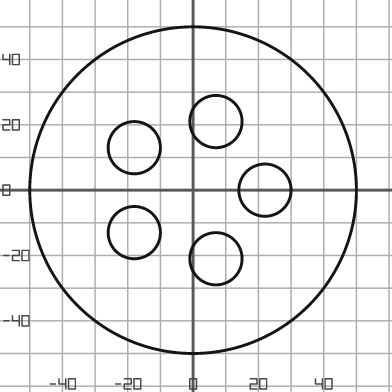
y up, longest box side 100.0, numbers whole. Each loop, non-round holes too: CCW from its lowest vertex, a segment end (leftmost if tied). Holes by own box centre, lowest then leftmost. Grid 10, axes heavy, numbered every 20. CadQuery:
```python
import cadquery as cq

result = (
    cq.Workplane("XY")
    .moveTo(0.0, 0.0)
    .circle(50.0)
    .moveTo(7.0, -21.0)
    .circle(8.0)
    .moveTo(-18.0, -13.0)
    .circle(8.0)
    .moveTo(22.0, 0.0)
    .circle(8.0)
    .moveTo(-18.0, 13.0)
    .circle(8.0)
    .moveTo(7.0, 21.0)
    .circle(8.0)
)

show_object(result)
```